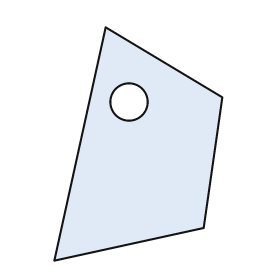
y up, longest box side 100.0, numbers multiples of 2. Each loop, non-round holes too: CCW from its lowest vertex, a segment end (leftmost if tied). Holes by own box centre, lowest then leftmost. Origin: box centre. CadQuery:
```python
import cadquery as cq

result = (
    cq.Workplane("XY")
    .moveTo(-36.0, -50.0)
    .lineTo(28.0, -36.0)
    .lineTo(36.0, 20.0)
    .lineTo(-14.0, 50.0)
    .close()
    .moveTo(-4.0, 18.0)
    .circle(8.0)
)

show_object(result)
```